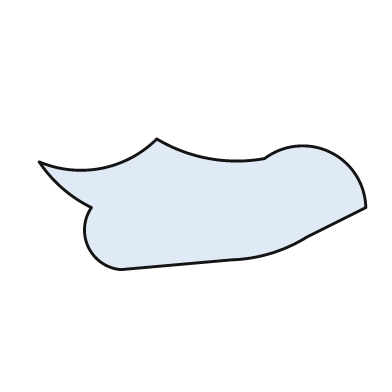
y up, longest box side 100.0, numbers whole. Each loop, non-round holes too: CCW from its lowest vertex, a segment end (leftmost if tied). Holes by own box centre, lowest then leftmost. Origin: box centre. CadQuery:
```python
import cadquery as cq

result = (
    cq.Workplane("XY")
    .moveTo(-25.0, -20.0)
    .lineTo(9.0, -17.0)
    .threePointArc((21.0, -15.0), (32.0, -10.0))
    .lineTo(50.0, -1.0)
    .threePointArc((39.0, 16.0), (19.0, 14.0))
    .threePointArc((2.0, 14.0), (-14.0, 20.0))
    .threePointArc((-31.0, 11.0), (-50.0, 13.0))
    .threePointArc((-43.0, 5.0), (-34.0, -1.0))
    .threePointArc((-35.0, -13.0), (-25.0, -20.0))
    .close()
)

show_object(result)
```